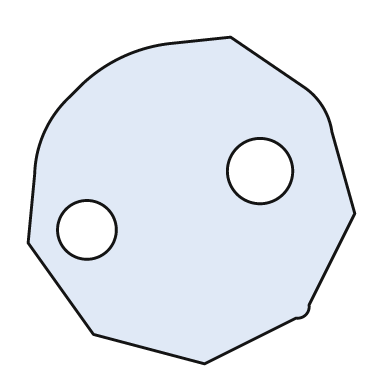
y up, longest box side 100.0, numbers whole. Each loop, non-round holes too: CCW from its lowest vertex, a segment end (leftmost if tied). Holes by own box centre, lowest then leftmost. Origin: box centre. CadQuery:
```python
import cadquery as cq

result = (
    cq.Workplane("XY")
    .moveTo(4.0, -50.0)
    .lineTo(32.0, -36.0)
    .threePointArc((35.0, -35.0), (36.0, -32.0))
    .lineTo(50.0, -4.0)
    .lineTo(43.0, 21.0)
    .threePointArc((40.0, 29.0), (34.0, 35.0))
    .lineTo(12.0, 50.0)
    .lineTo(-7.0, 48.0)
    .threePointArc((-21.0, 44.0), (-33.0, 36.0))
    .lineTo(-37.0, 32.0)
    .threePointArc((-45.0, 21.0), (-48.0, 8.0))
    .lineTo(-50.0, -13.0)
    .lineTo(-30.0, -41.0)
    .close()
    .moveTo(-32.0, -9.0)
    .circle(9.0)
    .moveTo(21.0, 9.0)
    .circle(10.0)
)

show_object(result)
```